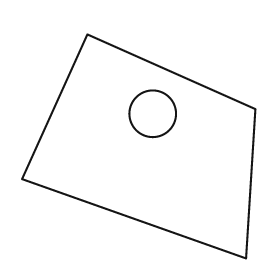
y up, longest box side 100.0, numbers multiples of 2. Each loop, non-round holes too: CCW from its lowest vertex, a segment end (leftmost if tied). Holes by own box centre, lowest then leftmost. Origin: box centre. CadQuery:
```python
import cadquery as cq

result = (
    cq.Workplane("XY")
    .moveTo(46.0, -48.0)
    .lineTo(50.0, 16.0)
    .lineTo(-22.0, 48.0)
    .lineTo(-50.0, -14.0)
    .close()
    .moveTo(6.0, 14.0)
    .circle(10.0)
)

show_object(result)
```